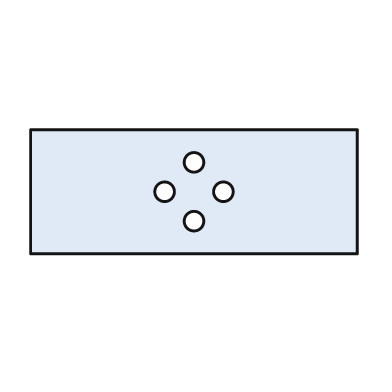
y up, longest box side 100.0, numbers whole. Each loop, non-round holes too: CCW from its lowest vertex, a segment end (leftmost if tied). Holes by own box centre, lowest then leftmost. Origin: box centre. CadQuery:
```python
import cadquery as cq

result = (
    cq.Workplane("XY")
    .moveTo(-50.0, -19.0)
    .lineTo(50.0, -19.0)
    .lineTo(50.0, 19.0)
    .lineTo(-50.0, 19.0)
    .close()
    .moveTo(0.0, -9.0)
    .circle(3.0)
    .moveTo(-9.0, 0.0)
    .circle(3.0)
    .moveTo(9.0, 0.0)
    .circle(3.0)
    .moveTo(0.0, 9.0)
    .circle(3.0)
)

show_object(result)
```